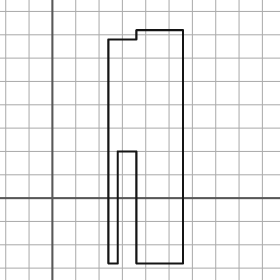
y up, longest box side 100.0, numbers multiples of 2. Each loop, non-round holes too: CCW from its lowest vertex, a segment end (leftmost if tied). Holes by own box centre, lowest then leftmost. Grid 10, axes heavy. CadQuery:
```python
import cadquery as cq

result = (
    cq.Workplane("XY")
    .moveTo(24.0, -28.0)
    .lineTo(28.0, -28.0)
    .lineTo(28.0, 20.0)
    .lineTo(36.0, 20.0)
    .lineTo(36.0, -28.0)
    .lineTo(56.0, -28.0)
    .lineTo(56.0, 72.0)
    .lineTo(36.0, 72.0)
    .lineTo(36.0, 68.0)
    .lineTo(24.0, 68.0)
    .close()
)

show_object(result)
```